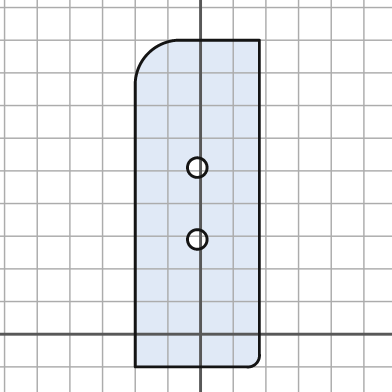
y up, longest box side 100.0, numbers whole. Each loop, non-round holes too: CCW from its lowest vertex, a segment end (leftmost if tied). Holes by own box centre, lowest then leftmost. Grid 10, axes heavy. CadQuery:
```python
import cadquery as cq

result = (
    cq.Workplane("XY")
    .moveTo(-20.0, -10.0)
    .lineTo(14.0, -10.0)
    .threePointArc((17.0, -9.0), (18.0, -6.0))
    .lineTo(18.0, 90.0)
    .lineTo(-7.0, 90.0)
    .threePointArc((-16.0, 86.0), (-20.0, 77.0))
    .close()
    .moveTo(-1.0, 29.0)
    .circle(3.0)
    .moveTo(-1.0, 51.0)
    .circle(3.0)
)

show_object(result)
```